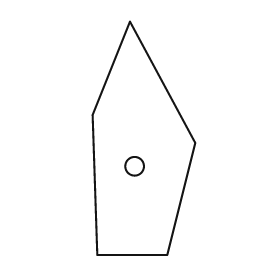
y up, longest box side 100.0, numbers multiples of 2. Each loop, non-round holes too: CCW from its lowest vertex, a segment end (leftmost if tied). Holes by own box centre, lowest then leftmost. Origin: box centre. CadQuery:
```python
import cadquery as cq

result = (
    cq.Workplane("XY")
    .moveTo(-20.0, -50.0)
    .lineTo(10.0, -50.0)
    .lineTo(22.0, -2.0)
    .lineTo(-6.0, 50.0)
    .lineTo(-22.0, 10.0)
    .close()
    .moveTo(-4.0, -12.0)
    .circle(4.0)
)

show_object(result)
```